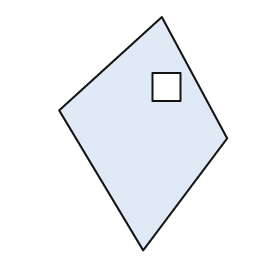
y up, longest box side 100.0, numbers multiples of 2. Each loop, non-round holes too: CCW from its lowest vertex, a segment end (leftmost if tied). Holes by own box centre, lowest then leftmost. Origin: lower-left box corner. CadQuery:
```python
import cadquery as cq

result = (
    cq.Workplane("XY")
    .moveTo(36.0, 0.0)
    .lineTo(72.0, 48.0)
    .lineTo(44.0, 100.0)
    .lineTo(0.0, 60.0)
    .close()
    .moveTo(40.0, 64.0)
    .lineTo(52.0, 64.0)
    .lineTo(52.0, 76.0)
    .lineTo(40.0, 76.0)
    .close()
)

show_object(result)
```